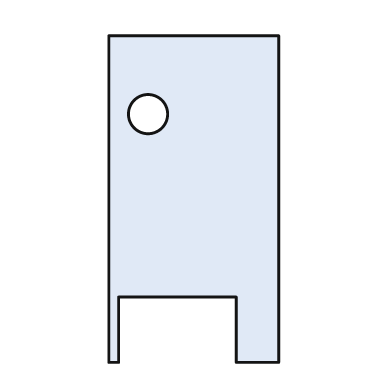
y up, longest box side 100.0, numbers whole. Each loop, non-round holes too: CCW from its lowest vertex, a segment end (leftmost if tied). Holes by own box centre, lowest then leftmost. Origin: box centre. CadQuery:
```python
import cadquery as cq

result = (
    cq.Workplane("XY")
    .moveTo(-26.0, -50.0)
    .lineTo(-23.0, -50.0)
    .lineTo(-23.0, -30.0)
    .lineTo(13.0, -30.0)
    .lineTo(13.0, -50.0)
    .lineTo(26.0, -50.0)
    .lineTo(26.0, 50.0)
    .lineTo(-26.0, 50.0)
    .close()
    .moveTo(-14.0, 26.0)
    .circle(6.0)
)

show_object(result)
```